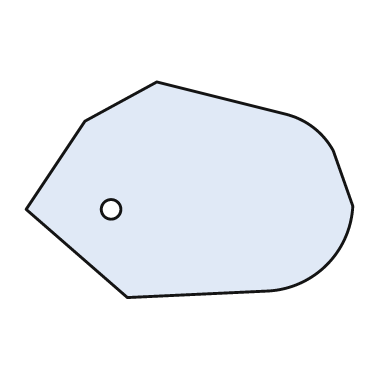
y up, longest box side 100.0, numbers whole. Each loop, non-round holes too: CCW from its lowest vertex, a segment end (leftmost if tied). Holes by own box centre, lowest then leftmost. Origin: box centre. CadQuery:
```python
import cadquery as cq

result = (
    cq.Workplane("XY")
    .moveTo(-19.0, -33.0)
    .lineTo(24.0, -31.0)
    .threePointArc((42.0, -23.0), (50.0, -5.0))
    .lineTo(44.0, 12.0)
    .threePointArc((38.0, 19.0), (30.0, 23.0))
    .lineTo(-10.0, 33.0)
    .lineTo(-32.0, 21.0)
    .lineTo(-50.0, -6.0)
    .close()
    .moveTo(-24.0, -6.0)
    .circle(3.0)
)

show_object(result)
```